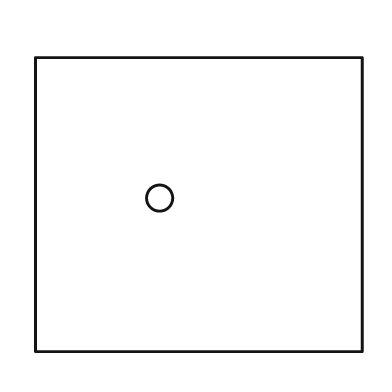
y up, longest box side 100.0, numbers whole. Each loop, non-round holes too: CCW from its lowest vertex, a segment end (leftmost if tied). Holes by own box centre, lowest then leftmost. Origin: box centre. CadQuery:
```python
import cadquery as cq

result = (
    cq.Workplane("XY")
    .moveTo(-50.0, -45.0)
    .lineTo(50.0, -45.0)
    .lineTo(50.0, 45.0)
    .lineTo(-50.0, 45.0)
    .close()
    .moveTo(-12.0, 2.0)
    .circle(4.0)
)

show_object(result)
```